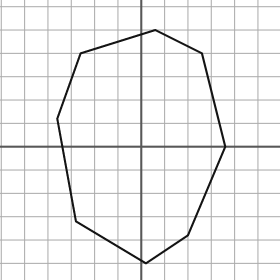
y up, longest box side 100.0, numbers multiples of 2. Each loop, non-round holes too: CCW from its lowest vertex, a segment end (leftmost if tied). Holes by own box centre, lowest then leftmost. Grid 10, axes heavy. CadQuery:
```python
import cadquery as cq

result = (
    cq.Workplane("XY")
    .moveTo(2.0, -50.0)
    .lineTo(20.0, -38.0)
    .lineTo(36.0, 0.0)
    .lineTo(26.0, 40.0)
    .lineTo(6.0, 50.0)
    .lineTo(-26.0, 40.0)
    .lineTo(-36.0, 12.0)
    .lineTo(-28.0, -32.0)
    .close()
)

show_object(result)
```